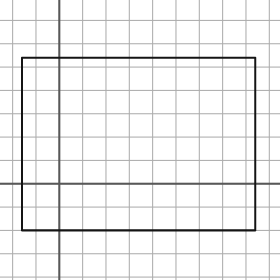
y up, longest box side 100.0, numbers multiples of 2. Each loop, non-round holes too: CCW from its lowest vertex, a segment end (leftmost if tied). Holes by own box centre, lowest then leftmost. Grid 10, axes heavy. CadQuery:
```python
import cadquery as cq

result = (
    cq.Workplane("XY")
    .moveTo(-16.0, -20.0)
    .lineTo(84.0, -20.0)
    .lineTo(84.0, 54.0)
    .lineTo(-16.0, 54.0)
    .close()
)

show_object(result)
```